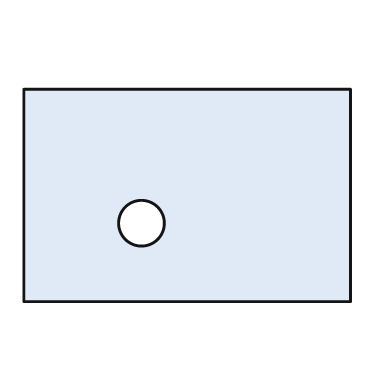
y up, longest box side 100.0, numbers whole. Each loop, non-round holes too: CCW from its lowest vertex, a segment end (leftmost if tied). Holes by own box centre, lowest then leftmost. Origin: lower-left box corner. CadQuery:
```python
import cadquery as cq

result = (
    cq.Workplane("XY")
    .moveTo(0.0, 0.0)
    .lineTo(100.0, 0.0)
    .lineTo(100.0, 65.0)
    .lineTo(0.0, 65.0)
    .close()
    .moveTo(36.0, 24.0)
    .circle(7.0)
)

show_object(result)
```